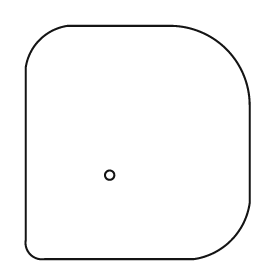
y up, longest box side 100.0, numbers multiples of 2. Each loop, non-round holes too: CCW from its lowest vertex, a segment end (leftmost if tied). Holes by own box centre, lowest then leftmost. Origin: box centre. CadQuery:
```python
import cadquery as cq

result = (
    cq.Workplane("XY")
    .moveTo(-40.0, -50.0)
    .lineTo(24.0, -50.0)
    .threePointArc((40.0, -42.0), (48.0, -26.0))
    .lineTo(48.0, 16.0)
    .threePointArc((38.0, 40.0), (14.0, 50.0))
    .lineTo(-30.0, 50.0)
    .threePointArc((-42.0, 44.0), (-48.0, 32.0))
    .lineTo(-48.0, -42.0)
    .threePointArc((-46.0, -48.0), (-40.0, -50.0))
    .close()
    .moveTo(-12.0, -14.0)
    .circle(2.0)
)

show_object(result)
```